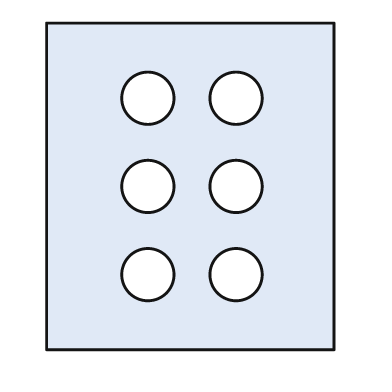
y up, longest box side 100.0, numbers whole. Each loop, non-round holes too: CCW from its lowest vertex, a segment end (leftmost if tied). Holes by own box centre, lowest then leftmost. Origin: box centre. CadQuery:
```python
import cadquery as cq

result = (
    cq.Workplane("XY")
    .moveTo(-44.0, -50.0)
    .lineTo(44.0, -50.0)
    .lineTo(44.0, 50.0)
    .lineTo(-44.0, 50.0)
    .close()
    .moveTo(-13.0, -27.0)
    .circle(8.0)
    .moveTo(14.0, -27.0)
    .circle(8.0)
    .moveTo(-13.0, 0.0)
    .circle(8.0)
    .moveTo(14.0, 0.0)
    .circle(8.0)
    .moveTo(-13.0, 27.0)
    .circle(8.0)
    .moveTo(14.0, 27.0)
    .circle(8.0)
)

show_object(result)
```